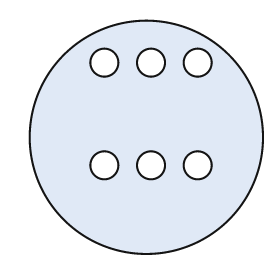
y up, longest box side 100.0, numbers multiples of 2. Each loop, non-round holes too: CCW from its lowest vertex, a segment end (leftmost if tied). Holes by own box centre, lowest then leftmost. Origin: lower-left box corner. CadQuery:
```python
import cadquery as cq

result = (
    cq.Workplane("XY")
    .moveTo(50.0, 50.0)
    .circle(50.0)
    .moveTo(32.0, 38.0)
    .circle(6.0)
    .moveTo(52.0, 38.0)
    .circle(6.0)
    .moveTo(72.0, 38.0)
    .circle(6.0)
    .moveTo(32.0, 82.0)
    .circle(6.0)
    .moveTo(52.0, 82.0)
    .circle(6.0)
    .moveTo(72.0, 82.0)
    .circle(6.0)
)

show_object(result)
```